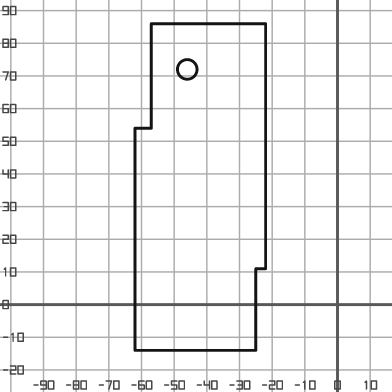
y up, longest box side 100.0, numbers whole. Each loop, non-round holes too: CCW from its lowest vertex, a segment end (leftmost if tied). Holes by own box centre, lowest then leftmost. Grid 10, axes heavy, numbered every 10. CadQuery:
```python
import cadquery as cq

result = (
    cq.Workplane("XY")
    .moveTo(-62.0, -14.0)
    .lineTo(-25.0, -14.0)
    .lineTo(-25.0, 11.0)
    .lineTo(-22.0, 11.0)
    .lineTo(-22.0, 86.0)
    .lineTo(-57.0, 86.0)
    .lineTo(-57.0, 54.0)
    .lineTo(-62.0, 54.0)
    .close()
    .moveTo(-46.0, 72.0)
    .circle(3.0)
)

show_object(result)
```